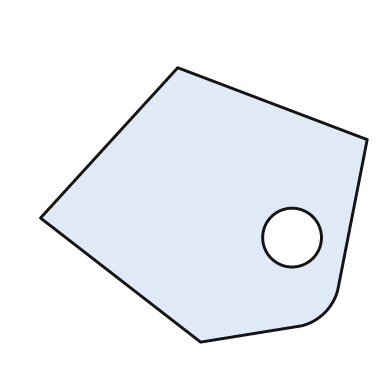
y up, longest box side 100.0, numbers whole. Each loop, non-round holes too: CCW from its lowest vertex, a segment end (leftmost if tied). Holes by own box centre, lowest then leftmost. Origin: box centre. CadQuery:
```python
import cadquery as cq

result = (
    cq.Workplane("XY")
    .moveTo(-1.0, -42.0)
    .lineTo(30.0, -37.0)
    .threePointArc((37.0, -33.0), (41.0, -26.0))
    .lineTo(50.0, 20.0)
    .lineTo(-8.0, 42.0)
    .lineTo(-50.0, -4.0)
    .close()
    .moveTo(27.0, -10.0)
    .circle(9.0)
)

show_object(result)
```